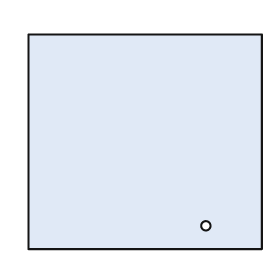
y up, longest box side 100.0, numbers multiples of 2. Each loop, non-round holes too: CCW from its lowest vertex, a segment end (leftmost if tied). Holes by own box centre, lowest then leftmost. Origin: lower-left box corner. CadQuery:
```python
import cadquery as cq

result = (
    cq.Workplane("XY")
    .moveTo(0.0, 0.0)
    .lineTo(100.0, 0.0)
    .lineTo(100.0, 92.0)
    .lineTo(0.0, 92.0)
    .close()
    .moveTo(76.0, 10.0)
    .circle(2.0)
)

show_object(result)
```